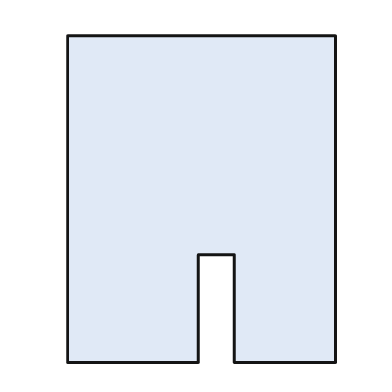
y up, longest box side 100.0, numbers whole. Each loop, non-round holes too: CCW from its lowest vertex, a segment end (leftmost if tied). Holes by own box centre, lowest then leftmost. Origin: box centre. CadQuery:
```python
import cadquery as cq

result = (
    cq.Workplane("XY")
    .moveTo(-41.0, -50.0)
    .lineTo(-1.0, -50.0)
    .lineTo(-1.0, -17.0)
    .lineTo(10.0, -17.0)
    .lineTo(10.0, -50.0)
    .lineTo(41.0, -50.0)
    .lineTo(41.0, 50.0)
    .lineTo(-41.0, 50.0)
    .close()
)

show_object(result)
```